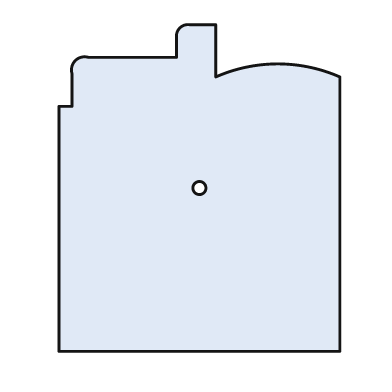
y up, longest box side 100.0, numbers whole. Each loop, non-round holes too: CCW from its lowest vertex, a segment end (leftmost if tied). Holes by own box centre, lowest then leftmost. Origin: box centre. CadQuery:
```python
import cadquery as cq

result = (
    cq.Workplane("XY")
    .moveTo(-43.0, -50.0)
    .lineTo(43.0, -50.0)
    .lineTo(43.0, 34.0)
    .threePointArc((24.0, 38.0), (5.0, 34.0))
    .lineTo(5.0, 50.0)
    .lineTo(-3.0, 50.0)
    .threePointArc((-6.0, 49.0), (-7.0, 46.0))
    .lineTo(-7.0, 40.0)
    .lineTo(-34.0, 40.0)
    .threePointArc((-38.0, 39.0), (-39.0, 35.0))
    .lineTo(-39.0, 25.0)
    .lineTo(-43.0, 25.0)
    .close()
    .moveTo(0.0, 0.0)
    .circle(2.0)
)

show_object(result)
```